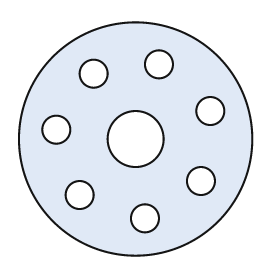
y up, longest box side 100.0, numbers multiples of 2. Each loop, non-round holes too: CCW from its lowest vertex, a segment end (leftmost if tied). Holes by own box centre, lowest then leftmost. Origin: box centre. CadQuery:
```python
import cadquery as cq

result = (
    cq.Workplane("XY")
    .moveTo(0.0, 0.0)
    .circle(50.0)
    .moveTo(4.0, -34.0)
    .circle(6.0)
    .moveTo(-24.0, -24.0)
    .circle(6.0)
    .moveTo(28.0, -18.0)
    .circle(6.0)
    .moveTo(0.0, 0.0)
    .circle(12.0)
    .moveTo(-34.0, 4.0)
    .circle(6.0)
    .moveTo(32.0, 12.0)
    .circle(6.0)
    .moveTo(-18.0, 28.0)
    .circle(6.0)
    .moveTo(10.0, 32.0)
    .circle(6.0)
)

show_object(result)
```